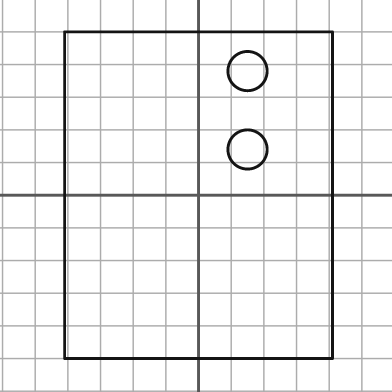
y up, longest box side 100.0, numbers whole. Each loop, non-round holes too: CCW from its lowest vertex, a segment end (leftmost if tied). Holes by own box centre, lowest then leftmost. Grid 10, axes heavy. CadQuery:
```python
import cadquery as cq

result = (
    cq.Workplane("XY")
    .moveTo(-41.0, -50.0)
    .lineTo(41.0, -50.0)
    .lineTo(41.0, 50.0)
    .lineTo(-41.0, 50.0)
    .close()
    .moveTo(15.0, 14.0)
    .circle(6.0)
    .moveTo(15.0, 38.0)
    .circle(6.0)
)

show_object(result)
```